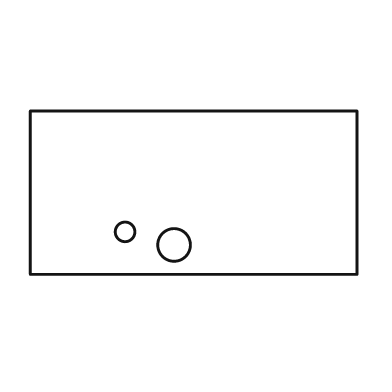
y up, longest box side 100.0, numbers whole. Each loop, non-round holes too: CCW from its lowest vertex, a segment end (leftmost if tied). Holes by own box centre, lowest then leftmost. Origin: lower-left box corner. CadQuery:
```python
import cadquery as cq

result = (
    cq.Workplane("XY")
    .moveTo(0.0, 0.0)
    .lineTo(100.0, 0.0)
    .lineTo(100.0, 50.0)
    .lineTo(0.0, 50.0)
    .close()
    .moveTo(44.0, 9.0)
    .circle(5.0)
    .moveTo(29.0, 13.0)
    .circle(3.0)
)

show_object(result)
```